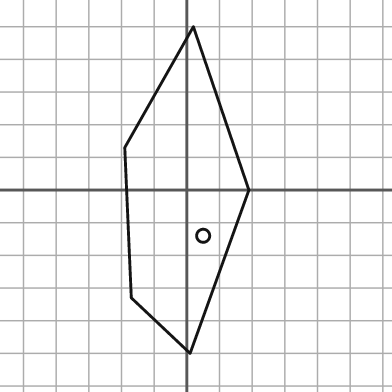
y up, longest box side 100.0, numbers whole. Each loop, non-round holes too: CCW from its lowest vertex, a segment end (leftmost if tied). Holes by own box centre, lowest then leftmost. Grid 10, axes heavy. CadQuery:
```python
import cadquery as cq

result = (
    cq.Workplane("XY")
    .moveTo(1.0, -50.0)
    .lineTo(19.0, 0.0)
    .lineTo(2.0, 50.0)
    .lineTo(-19.0, 13.0)
    .lineTo(-17.0, -33.0)
    .close()
    .moveTo(5.0, -14.0)
    .circle(2.0)
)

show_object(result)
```